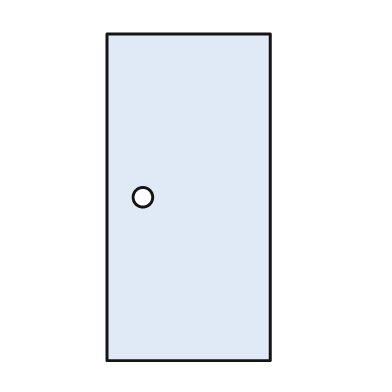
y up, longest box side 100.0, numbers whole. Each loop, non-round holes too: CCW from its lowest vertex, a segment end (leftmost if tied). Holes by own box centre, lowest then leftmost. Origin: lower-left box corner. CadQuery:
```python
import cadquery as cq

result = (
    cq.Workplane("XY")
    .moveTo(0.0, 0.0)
    .lineTo(50.0, 0.0)
    .lineTo(50.0, 100.0)
    .lineTo(0.0, 100.0)
    .close()
    .moveTo(11.0, 50.0)
    .circle(3.0)
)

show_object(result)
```